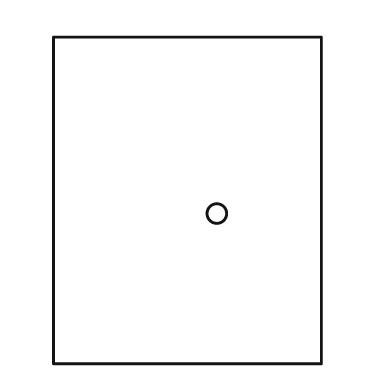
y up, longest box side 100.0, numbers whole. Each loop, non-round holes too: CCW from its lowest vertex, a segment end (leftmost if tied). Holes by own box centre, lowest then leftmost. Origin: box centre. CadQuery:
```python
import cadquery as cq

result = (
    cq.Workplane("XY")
    .moveTo(-41.0, -50.0)
    .lineTo(41.0, -50.0)
    .lineTo(41.0, 50.0)
    .lineTo(-41.0, 50.0)
    .close()
    .moveTo(9.0, -4.0)
    .circle(3.0)
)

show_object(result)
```